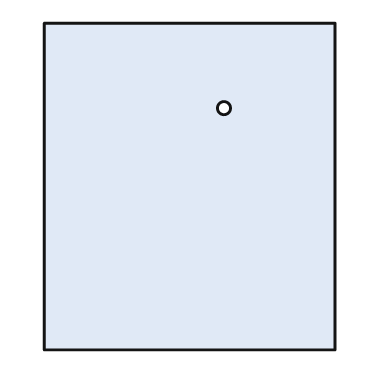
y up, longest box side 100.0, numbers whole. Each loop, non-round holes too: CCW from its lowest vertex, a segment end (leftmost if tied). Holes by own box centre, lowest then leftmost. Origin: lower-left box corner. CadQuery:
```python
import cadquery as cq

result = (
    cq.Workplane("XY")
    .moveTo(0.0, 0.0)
    .lineTo(89.0, 0.0)
    .lineTo(89.0, 100.0)
    .lineTo(0.0, 100.0)
    .close()
    .moveTo(55.0, 74.0)
    .circle(2.0)
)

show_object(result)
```